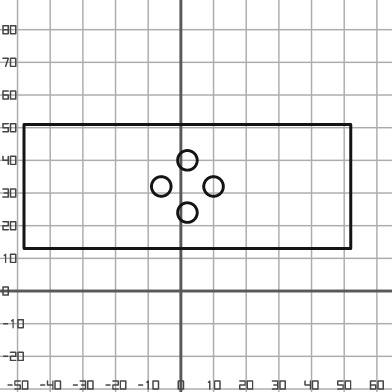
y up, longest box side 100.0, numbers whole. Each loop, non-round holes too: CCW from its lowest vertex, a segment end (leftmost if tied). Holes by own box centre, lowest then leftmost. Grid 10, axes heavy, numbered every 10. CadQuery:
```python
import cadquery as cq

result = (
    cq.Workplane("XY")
    .moveTo(-48.0, 13.0)
    .lineTo(52.0, 13.0)
    .lineTo(52.0, 51.0)
    .lineTo(-48.0, 51.0)
    .close()
    .moveTo(2.0, 24.0)
    .circle(3.0)
    .moveTo(-6.0, 32.0)
    .circle(3.0)
    .moveTo(10.0, 32.0)
    .circle(3.0)
    .moveTo(2.0, 40.0)
    .circle(3.0)
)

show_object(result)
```